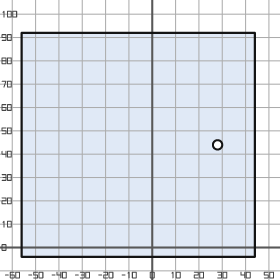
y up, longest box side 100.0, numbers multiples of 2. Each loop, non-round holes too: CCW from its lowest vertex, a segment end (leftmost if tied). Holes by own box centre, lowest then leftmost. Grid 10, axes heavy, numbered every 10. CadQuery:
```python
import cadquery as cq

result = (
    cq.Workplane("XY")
    .moveTo(-56.0, -4.0)
    .lineTo(44.0, -4.0)
    .lineTo(44.0, 92.0)
    .lineTo(-56.0, 92.0)
    .close()
    .moveTo(28.0, 44.0)
    .circle(2.0)
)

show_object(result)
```